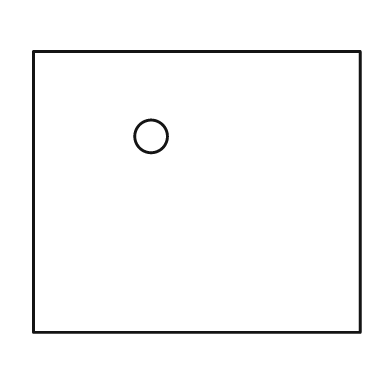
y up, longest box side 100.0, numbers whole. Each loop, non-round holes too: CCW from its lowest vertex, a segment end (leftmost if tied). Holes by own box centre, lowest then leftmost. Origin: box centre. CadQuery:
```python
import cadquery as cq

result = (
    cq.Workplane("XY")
    .moveTo(-50.0, -43.0)
    .lineTo(50.0, -43.0)
    .lineTo(50.0, 43.0)
    .lineTo(-50.0, 43.0)
    .close()
    .moveTo(-14.0, 17.0)
    .circle(5.0)
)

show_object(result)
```